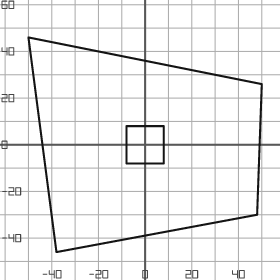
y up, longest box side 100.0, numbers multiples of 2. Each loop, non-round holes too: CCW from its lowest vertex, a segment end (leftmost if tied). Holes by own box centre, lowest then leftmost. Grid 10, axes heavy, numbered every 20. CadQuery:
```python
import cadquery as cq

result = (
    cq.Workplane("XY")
    .moveTo(-38.0, -46.0)
    .lineTo(48.0, -30.0)
    .lineTo(50.0, 26.0)
    .lineTo(-50.0, 46.0)
    .close()
    .moveTo(-8.0, -8.0)
    .lineTo(8.0, -8.0)
    .lineTo(8.0, 8.0)
    .lineTo(-8.0, 8.0)
    .close()
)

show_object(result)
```